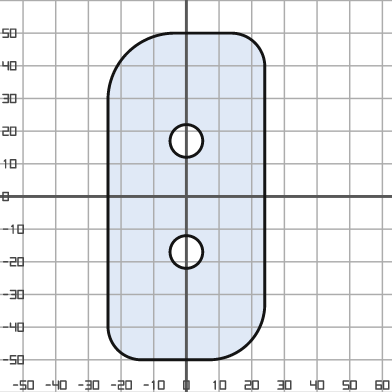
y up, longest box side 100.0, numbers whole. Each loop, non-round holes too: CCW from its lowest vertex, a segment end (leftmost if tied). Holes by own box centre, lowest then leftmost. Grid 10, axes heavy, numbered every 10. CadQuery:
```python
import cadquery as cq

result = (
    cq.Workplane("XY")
    .moveTo(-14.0, -50.0)
    .lineTo(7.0, -50.0)
    .threePointArc((19.0, -45.0), (24.0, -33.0))
    .lineTo(24.0, 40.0)
    .threePointArc((21.0, 47.0), (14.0, 50.0))
    .lineTo(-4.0, 50.0)
    .threePointArc((-18.0, 44.0), (-24.0, 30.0))
    .lineTo(-24.0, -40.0)
    .threePointArc((-21.0, -47.0), (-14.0, -50.0))
    .close()
    .moveTo(0.0, -17.0)
    .circle(5.0)
    .moveTo(0.0, 17.0)
    .circle(5.0)
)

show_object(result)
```